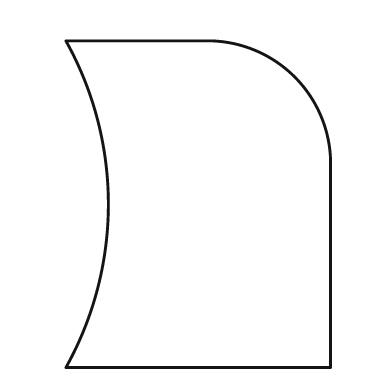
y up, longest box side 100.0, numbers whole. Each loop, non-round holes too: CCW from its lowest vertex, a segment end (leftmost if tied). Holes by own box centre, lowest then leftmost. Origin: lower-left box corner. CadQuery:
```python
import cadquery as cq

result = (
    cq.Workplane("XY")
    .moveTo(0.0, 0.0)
    .lineTo(81.0, 0.0)
    .lineTo(81.0, 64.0)
    .threePointArc((70.0, 89.0), (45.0, 100.0))
    .lineTo(0.0, 100.0)
    .threePointArc((13.0, 50.0), (0.0, 0.0))
    .close()
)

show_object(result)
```